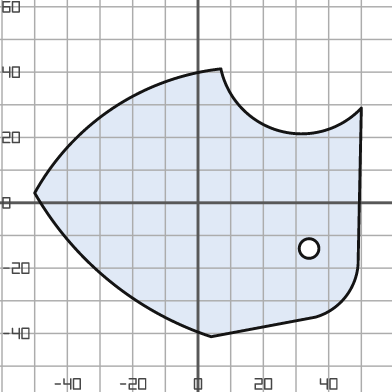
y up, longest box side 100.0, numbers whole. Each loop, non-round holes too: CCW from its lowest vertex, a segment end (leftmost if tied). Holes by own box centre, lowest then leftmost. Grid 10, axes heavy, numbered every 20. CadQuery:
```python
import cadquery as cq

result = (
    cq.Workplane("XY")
    .moveTo(4.0, -41.0)
    .lineTo(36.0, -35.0)
    .threePointArc((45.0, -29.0), (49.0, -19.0))
    .lineTo(50.0, 29.0)
    .threePointArc((25.0, 22.0), (7.0, 41.0))
    .threePointArc((-26.0, 29.0), (-50.0, 3.0))
    .threePointArc((-27.0, -24.0), (4.0, -41.0))
    .close()
    .moveTo(34.0, -14.0)
    .circle(3.0)
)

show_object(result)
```